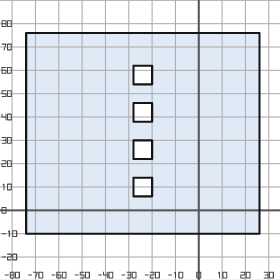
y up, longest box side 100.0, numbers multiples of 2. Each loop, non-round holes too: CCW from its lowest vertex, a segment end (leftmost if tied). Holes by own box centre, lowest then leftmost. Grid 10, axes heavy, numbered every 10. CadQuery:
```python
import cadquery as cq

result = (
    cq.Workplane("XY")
    .moveTo(-74.0, -10.0)
    .lineTo(26.0, -10.0)
    .lineTo(26.0, 76.0)
    .lineTo(-74.0, 76.0)
    .close()
    .moveTo(-28.0, 6.0)
    .lineTo(-20.0, 6.0)
    .lineTo(-20.0, 14.0)
    .lineTo(-28.0, 14.0)
    .close()
    .moveTo(-28.0, 22.0)
    .lineTo(-20.0, 22.0)
    .lineTo(-20.0, 30.0)
    .lineTo(-28.0, 30.0)
    .close()
    .moveTo(-28.0, 38.0)
    .lineTo(-20.0, 38.0)
    .lineTo(-20.0, 46.0)
    .lineTo(-28.0, 46.0)
    .close()
    .moveTo(-28.0, 54.0)
    .lineTo(-20.0, 54.0)
    .lineTo(-20.0, 62.0)
    .lineTo(-28.0, 62.0)
    .close()
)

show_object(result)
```